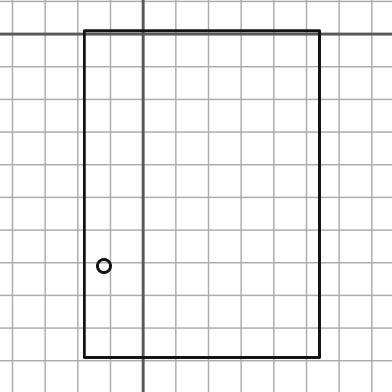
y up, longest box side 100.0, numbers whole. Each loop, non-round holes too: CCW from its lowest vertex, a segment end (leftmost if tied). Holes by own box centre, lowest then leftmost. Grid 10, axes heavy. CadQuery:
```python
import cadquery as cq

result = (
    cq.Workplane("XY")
    .moveTo(-18.0, -99.0)
    .lineTo(54.0, -99.0)
    .lineTo(54.0, 1.0)
    .lineTo(-18.0, 1.0)
    .close()
    .moveTo(-12.0, -71.0)
    .circle(2.0)
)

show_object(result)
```